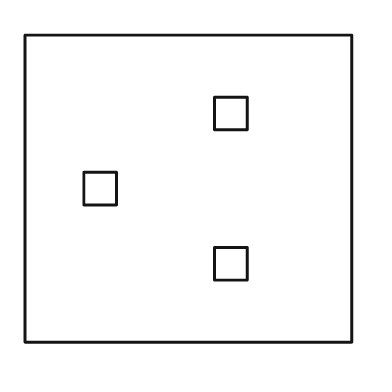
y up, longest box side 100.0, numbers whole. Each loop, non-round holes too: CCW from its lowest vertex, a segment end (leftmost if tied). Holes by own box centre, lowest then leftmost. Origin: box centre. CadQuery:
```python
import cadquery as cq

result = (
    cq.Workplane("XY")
    .moveTo(-50.0, -47.0)
    .lineTo(50.0, -47.0)
    .lineTo(50.0, 47.0)
    .lineTo(-50.0, 47.0)
    .close()
    .moveTo(8.0, -28.0)
    .lineTo(18.0, -28.0)
    .lineTo(18.0, -18.0)
    .lineTo(8.0, -18.0)
    .close()
    .moveTo(-32.0, -5.0)
    .lineTo(-22.0, -5.0)
    .lineTo(-22.0, 5.0)
    .lineTo(-32.0, 5.0)
    .close()
    .moveTo(8.0, 18.0)
    .lineTo(18.0, 18.0)
    .lineTo(18.0, 28.0)
    .lineTo(8.0, 28.0)
    .close()
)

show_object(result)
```